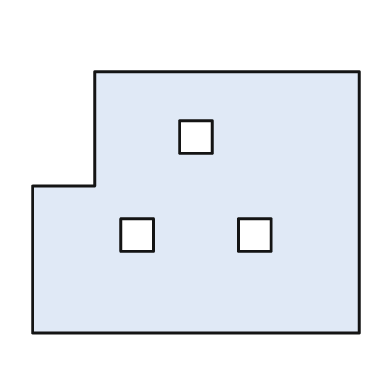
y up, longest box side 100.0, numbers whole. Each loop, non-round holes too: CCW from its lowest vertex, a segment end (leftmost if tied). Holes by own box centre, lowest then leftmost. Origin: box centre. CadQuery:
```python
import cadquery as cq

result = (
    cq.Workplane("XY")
    .moveTo(-50.0, -40.0)
    .lineTo(50.0, -40.0)
    .lineTo(50.0, 40.0)
    .lineTo(-31.0, 40.0)
    .lineTo(-31.0, 5.0)
    .lineTo(-50.0, 5.0)
    .close()
    .moveTo(-23.0, -15.0)
    .lineTo(-13.0, -15.0)
    .lineTo(-13.0, -5.0)
    .lineTo(-23.0, -5.0)
    .close()
    .moveTo(13.0, -15.0)
    .lineTo(23.0, -15.0)
    .lineTo(23.0, -5.0)
    .lineTo(13.0, -5.0)
    .close()
    .moveTo(-5.0, 15.0)
    .lineTo(5.0, 15.0)
    .lineTo(5.0, 25.0)
    .lineTo(-5.0, 25.0)
    .close()
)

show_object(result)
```